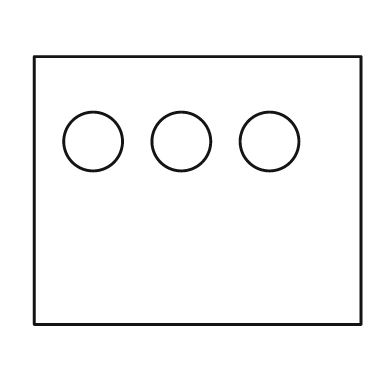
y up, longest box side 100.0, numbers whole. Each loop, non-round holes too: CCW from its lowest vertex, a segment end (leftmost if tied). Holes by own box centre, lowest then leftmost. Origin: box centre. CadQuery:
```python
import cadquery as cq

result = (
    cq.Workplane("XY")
    .moveTo(-50.0, -41.0)
    .lineTo(50.0, -41.0)
    .lineTo(50.0, 41.0)
    .lineTo(-50.0, 41.0)
    .close()
    .moveTo(-32.0, 15.0)
    .circle(9.0)
    .moveTo(-5.0, 15.0)
    .circle(9.0)
    .moveTo(22.0, 15.0)
    .circle(9.0)
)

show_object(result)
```